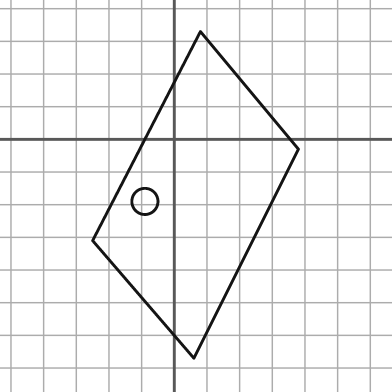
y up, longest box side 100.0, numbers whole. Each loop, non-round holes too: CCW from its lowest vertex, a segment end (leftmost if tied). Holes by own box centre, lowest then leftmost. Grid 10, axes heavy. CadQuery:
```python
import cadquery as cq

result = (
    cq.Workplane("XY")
    .moveTo(6.0, -67.0)
    .lineTo(38.0, -3.0)
    .lineTo(8.0, 33.0)
    .lineTo(-25.0, -31.0)
    .close()
    .moveTo(-9.0, -19.0)
    .circle(4.0)
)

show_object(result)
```